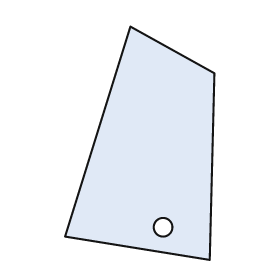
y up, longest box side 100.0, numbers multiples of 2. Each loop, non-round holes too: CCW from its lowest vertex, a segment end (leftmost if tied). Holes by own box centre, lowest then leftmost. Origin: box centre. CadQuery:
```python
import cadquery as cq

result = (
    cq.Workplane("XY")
    .moveTo(30.0, -50.0)
    .lineTo(32.0, 30.0)
    .lineTo(-4.0, 50.0)
    .lineTo(-32.0, -40.0)
    .close()
    .moveTo(10.0, -36.0)
    .circle(4.0)
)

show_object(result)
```